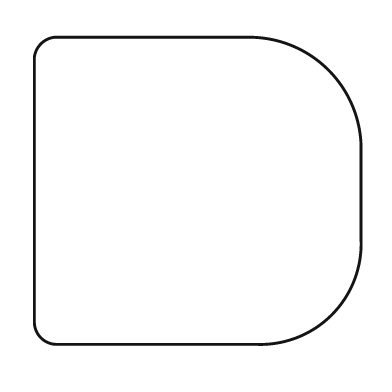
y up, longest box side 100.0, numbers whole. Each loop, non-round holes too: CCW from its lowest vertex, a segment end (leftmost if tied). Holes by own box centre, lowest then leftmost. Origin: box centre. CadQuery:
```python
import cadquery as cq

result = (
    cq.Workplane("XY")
    .moveTo(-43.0, -47.0)
    .lineTo(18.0, -47.0)
    .threePointArc((41.0, -38.0), (50.0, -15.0))
    .lineTo(50.0, 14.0)
    .threePointArc((40.0, 37.0), (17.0, 47.0))
    .lineTo(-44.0, 47.0)
    .threePointArc((-48.0, 45.0), (-50.0, 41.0))
    .lineTo(-50.0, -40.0)
    .threePointArc((-48.0, -45.0), (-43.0, -47.0))
    .close()
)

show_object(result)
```